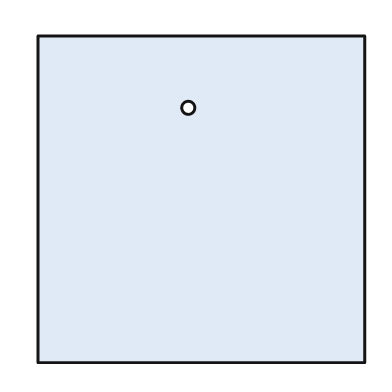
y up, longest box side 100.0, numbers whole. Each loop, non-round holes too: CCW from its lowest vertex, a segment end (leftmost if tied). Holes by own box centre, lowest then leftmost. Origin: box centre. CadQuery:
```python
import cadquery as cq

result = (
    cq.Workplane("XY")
    .moveTo(-50.0, -50.0)
    .lineTo(50.0, -50.0)
    .lineTo(50.0, 50.0)
    .lineTo(-50.0, 50.0)
    .close()
    .moveTo(-4.0, 28.0)
    .circle(2.0)
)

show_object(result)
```